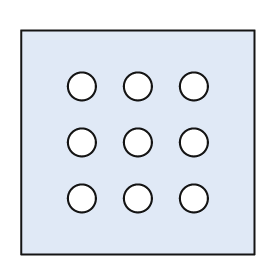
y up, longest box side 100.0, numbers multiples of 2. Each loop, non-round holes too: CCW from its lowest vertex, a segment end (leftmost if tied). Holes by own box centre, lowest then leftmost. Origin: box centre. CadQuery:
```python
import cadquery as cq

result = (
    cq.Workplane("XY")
    .moveTo(-50.0, -48.0)
    .lineTo(50.0, -48.0)
    .lineTo(50.0, 48.0)
    .lineTo(-50.0, 48.0)
    .close()
    .moveTo(-24.0, -24.0)
    .circle(6.0)
    .moveTo(0.0, -24.0)
    .circle(6.0)
    .moveTo(24.0, -24.0)
    .circle(6.0)
    .moveTo(-24.0, 0.0)
    .circle(6.0)
    .moveTo(0.0, 0.0)
    .circle(6.0)
    .moveTo(24.0, 0.0)
    .circle(6.0)
    .moveTo(-24.0, 24.0)
    .circle(6.0)
    .moveTo(0.0, 24.0)
    .circle(6.0)
    .moveTo(24.0, 24.0)
    .circle(6.0)
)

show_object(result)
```